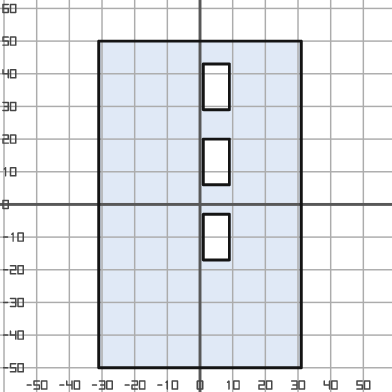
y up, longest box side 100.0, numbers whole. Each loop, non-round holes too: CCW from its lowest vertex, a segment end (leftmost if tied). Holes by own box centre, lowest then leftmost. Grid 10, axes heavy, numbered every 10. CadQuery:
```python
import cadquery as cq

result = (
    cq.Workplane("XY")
    .moveTo(-31.0, -50.0)
    .lineTo(31.0, -50.0)
    .lineTo(31.0, 50.0)
    .lineTo(-31.0, 50.0)
    .close()
    .moveTo(1.0, -17.0)
    .lineTo(9.0, -17.0)
    .lineTo(9.0, -3.0)
    .lineTo(1.0, -3.0)
    .close()
    .moveTo(1.0, 6.0)
    .lineTo(9.0, 6.0)
    .lineTo(9.0, 20.0)
    .lineTo(1.0, 20.0)
    .close()
    .moveTo(1.0, 29.0)
    .lineTo(9.0, 29.0)
    .lineTo(9.0, 43.0)
    .lineTo(1.0, 43.0)
    .close()
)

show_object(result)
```